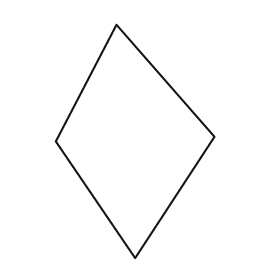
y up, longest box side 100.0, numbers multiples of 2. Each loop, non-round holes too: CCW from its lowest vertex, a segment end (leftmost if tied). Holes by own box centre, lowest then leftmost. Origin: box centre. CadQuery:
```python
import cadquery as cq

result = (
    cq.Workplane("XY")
    .moveTo(0.0, -50.0)
    .lineTo(34.0, 2.0)
    .lineTo(-8.0, 50.0)
    .lineTo(-34.0, 0.0)
    .close()
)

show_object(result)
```